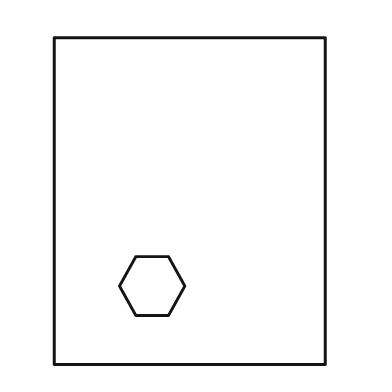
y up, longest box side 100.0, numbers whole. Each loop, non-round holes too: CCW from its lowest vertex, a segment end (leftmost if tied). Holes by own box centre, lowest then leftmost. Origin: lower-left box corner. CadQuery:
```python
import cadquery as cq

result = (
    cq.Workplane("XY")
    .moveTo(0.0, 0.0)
    .lineTo(83.0, 0.0)
    .lineTo(83.0, 100.0)
    .lineTo(0.0, 100.0)
    .close()
    .moveTo(25.0, 15.0)
    .lineTo(35.0, 15.0)
    .lineTo(40.0, 24.0)
    .lineTo(35.0, 33.0)
    .lineTo(25.0, 33.0)
    .lineTo(20.0, 24.0)
    .close()
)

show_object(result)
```